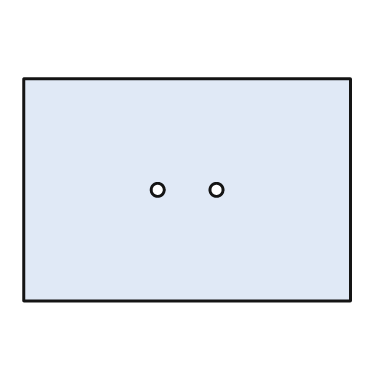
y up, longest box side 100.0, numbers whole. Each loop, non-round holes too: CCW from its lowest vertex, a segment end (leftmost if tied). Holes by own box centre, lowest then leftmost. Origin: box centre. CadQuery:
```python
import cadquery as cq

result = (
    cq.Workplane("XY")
    .moveTo(-50.0, -34.0)
    .lineTo(50.0, -34.0)
    .lineTo(50.0, 34.0)
    .lineTo(-50.0, 34.0)
    .close()
    .moveTo(-9.0, 0.0)
    .circle(2.0)
    .moveTo(9.0, 0.0)
    .circle(2.0)
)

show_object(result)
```